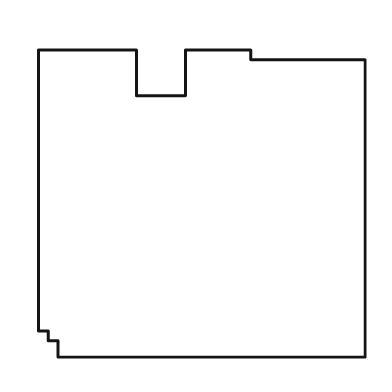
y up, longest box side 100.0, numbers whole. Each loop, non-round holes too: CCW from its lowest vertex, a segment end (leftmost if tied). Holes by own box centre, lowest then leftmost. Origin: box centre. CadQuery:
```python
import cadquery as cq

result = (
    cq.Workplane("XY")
    .moveTo(-44.0, -47.0)
    .lineTo(50.0, -47.0)
    .lineTo(50.0, 44.0)
    .lineTo(15.0, 44.0)
    .lineTo(15.0, 47.0)
    .lineTo(-5.0, 47.0)
    .lineTo(-5.0, 33.0)
    .lineTo(-20.0, 33.0)
    .lineTo(-20.0, 47.0)
    .lineTo(-50.0, 47.0)
    .lineTo(-50.0, -39.0)
    .lineTo(-47.0, -39.0)
    .lineTo(-47.0, -42.0)
    .lineTo(-44.0, -42.0)
    .close()
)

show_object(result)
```